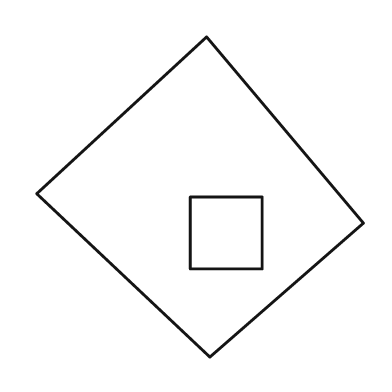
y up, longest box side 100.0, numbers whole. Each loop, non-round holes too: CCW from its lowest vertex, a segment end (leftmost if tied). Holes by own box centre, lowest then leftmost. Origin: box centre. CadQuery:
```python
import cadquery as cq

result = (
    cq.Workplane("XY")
    .moveTo(3.0, -49.0)
    .lineTo(50.0, -8.0)
    .lineTo(2.0, 49.0)
    .lineTo(-50.0, 1.0)
    .close()
    .moveTo(-3.0, -22.0)
    .lineTo(19.0, -22.0)
    .lineTo(19.0, 0.0)
    .lineTo(-3.0, 0.0)
    .close()
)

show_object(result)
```